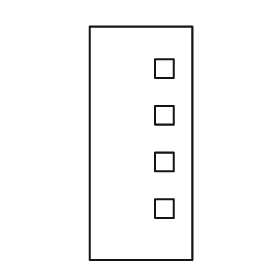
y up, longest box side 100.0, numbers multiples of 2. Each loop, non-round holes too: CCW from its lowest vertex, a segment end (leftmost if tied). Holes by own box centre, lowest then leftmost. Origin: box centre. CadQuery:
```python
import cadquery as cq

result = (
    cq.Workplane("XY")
    .moveTo(-22.0, -50.0)
    .lineTo(22.0, -50.0)
    .lineTo(22.0, 50.0)
    .lineTo(-22.0, 50.0)
    .close()
    .moveTo(6.0, -32.0)
    .lineTo(14.0, -32.0)
    .lineTo(14.0, -24.0)
    .lineTo(6.0, -24.0)
    .close()
    .moveTo(6.0, -12.0)
    .lineTo(14.0, -12.0)
    .lineTo(14.0, -4.0)
    .lineTo(6.0, -4.0)
    .close()
    .moveTo(6.0, 8.0)
    .lineTo(14.0, 8.0)
    .lineTo(14.0, 16.0)
    .lineTo(6.0, 16.0)
    .close()
    .moveTo(6.0, 28.0)
    .lineTo(14.0, 28.0)
    .lineTo(14.0, 36.0)
    .lineTo(6.0, 36.0)
    .close()
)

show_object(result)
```